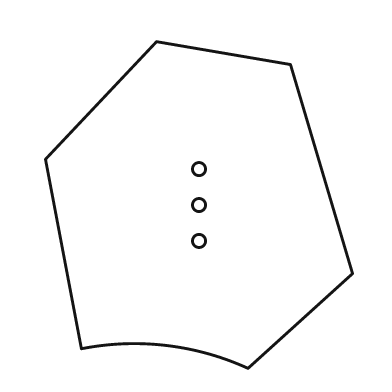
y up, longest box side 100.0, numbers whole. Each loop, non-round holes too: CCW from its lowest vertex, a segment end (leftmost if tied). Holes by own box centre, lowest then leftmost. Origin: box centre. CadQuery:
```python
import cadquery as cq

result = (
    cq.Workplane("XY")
    .moveTo(15.0, -50.0)
    .lineTo(47.0, -21.0)
    .lineTo(28.0, 43.0)
    .lineTo(-13.0, 50.0)
    .lineTo(-47.0, 14.0)
    .lineTo(-36.0, -44.0)
    .threePointArc((-10.0, -43.0), (15.0, -50.0))
    .close()
    .moveTo(0.0, -11.0)
    .circle(2.0)
    .moveTo(0.0, 0.0)
    .circle(2.0)
    .moveTo(0.0, 11.0)
    .circle(2.0)
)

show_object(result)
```